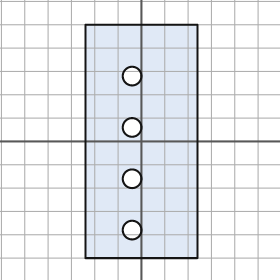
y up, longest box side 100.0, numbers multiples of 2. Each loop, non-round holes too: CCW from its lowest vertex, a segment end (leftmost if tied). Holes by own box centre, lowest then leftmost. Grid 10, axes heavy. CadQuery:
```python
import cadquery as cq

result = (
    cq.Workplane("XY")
    .moveTo(-24.0, -50.0)
    .lineTo(24.0, -50.0)
    .lineTo(24.0, 50.0)
    .lineTo(-24.0, 50.0)
    .close()
    .moveTo(-4.0, -38.0)
    .circle(4.0)
    .moveTo(-4.0, -16.0)
    .circle(4.0)
    .moveTo(-4.0, 6.0)
    .circle(4.0)
    .moveTo(-4.0, 28.0)
    .circle(4.0)
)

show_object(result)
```